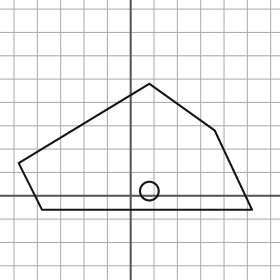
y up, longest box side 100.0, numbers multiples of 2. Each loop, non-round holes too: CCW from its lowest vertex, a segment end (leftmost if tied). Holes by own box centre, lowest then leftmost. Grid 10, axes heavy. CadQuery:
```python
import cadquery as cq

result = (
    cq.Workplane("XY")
    .moveTo(-38.0, -6.0)
    .lineTo(52.0, -6.0)
    .lineTo(36.0, 28.0)
    .lineTo(8.0, 48.0)
    .lineTo(-48.0, 14.0)
    .close()
    .moveTo(8.0, 2.0)
    .circle(4.0)
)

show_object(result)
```